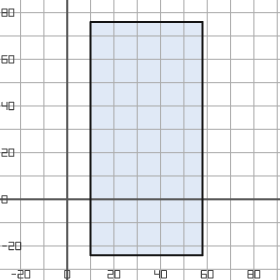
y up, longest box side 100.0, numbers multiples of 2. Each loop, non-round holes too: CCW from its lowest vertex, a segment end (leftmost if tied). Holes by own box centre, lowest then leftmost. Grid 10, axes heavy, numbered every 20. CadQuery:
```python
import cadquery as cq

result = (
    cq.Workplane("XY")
    .moveTo(10.0, -24.0)
    .lineTo(58.0, -24.0)
    .lineTo(58.0, 76.0)
    .lineTo(10.0, 76.0)
    .close()
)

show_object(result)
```